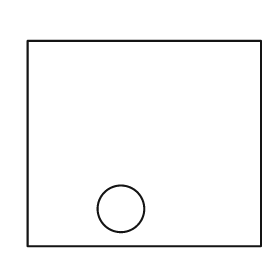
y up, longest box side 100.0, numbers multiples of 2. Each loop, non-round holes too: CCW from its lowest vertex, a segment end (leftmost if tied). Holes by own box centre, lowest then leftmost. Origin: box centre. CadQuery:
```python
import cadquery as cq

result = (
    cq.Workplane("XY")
    .moveTo(-50.0, -44.0)
    .lineTo(50.0, -44.0)
    .lineTo(50.0, 44.0)
    .lineTo(-50.0, 44.0)
    .close()
    .moveTo(-10.0, -28.0)
    .circle(10.0)
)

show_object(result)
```